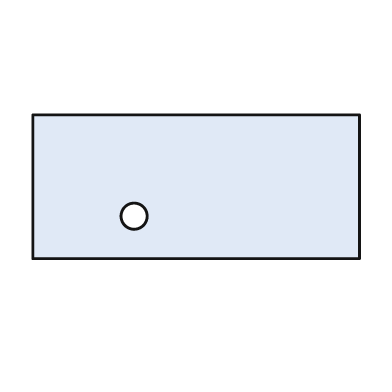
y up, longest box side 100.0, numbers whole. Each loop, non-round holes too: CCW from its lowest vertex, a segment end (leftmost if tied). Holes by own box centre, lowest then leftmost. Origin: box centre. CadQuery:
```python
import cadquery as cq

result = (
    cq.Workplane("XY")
    .moveTo(-50.0, -22.0)
    .lineTo(50.0, -22.0)
    .lineTo(50.0, 22.0)
    .lineTo(-50.0, 22.0)
    .close()
    .moveTo(-19.0, -9.0)
    .circle(4.0)
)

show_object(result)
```